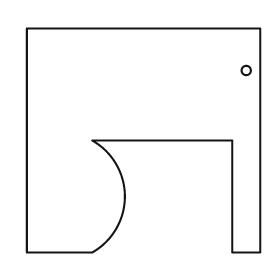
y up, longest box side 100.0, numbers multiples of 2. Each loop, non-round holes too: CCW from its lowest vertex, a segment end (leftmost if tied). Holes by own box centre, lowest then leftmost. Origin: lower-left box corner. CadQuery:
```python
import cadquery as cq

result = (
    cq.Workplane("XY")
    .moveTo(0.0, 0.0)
    .lineTo(28.0, 0.0)
    .threePointArc((42.0, 24.0), (28.0, 48.0))
    .lineTo(88.0, 48.0)
    .lineTo(88.0, 0.0)
    .lineTo(100.0, 0.0)
    .lineTo(100.0, 96.0)
    .lineTo(0.0, 96.0)
    .close()
    .moveTo(94.0, 78.0)
    .circle(2.0)
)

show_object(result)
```